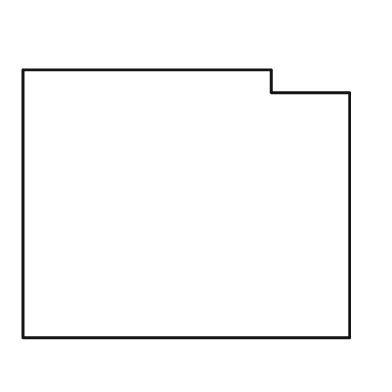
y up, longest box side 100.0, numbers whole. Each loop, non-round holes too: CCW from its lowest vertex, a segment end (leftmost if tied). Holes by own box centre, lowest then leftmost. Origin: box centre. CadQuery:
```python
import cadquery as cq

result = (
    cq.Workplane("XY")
    .moveTo(-50.0, -41.0)
    .lineTo(50.0, -41.0)
    .lineTo(50.0, 34.0)
    .lineTo(26.0, 34.0)
    .lineTo(26.0, 41.0)
    .lineTo(-50.0, 41.0)
    .close()
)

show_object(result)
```